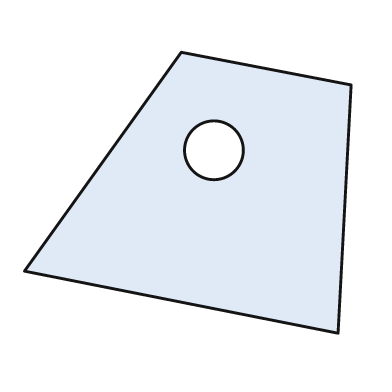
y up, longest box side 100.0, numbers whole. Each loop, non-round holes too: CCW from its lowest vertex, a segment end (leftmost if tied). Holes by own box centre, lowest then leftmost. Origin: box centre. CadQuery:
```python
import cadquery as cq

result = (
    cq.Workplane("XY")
    .moveTo(46.0, -43.0)
    .lineTo(50.0, 33.0)
    .lineTo(-2.0, 43.0)
    .lineTo(-50.0, -24.0)
    .close()
    .moveTo(8.0, 13.0)
    .circle(9.0)
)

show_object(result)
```